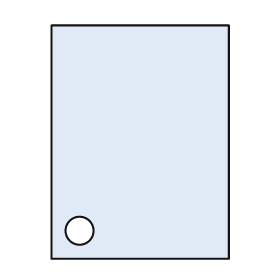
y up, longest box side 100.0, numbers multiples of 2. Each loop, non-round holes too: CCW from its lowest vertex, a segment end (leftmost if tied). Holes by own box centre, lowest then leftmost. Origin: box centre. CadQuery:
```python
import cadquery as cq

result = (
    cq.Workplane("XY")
    .moveTo(-38.0, -50.0)
    .lineTo(38.0, -50.0)
    .lineTo(38.0, 50.0)
    .lineTo(-38.0, 50.0)
    .close()
    .moveTo(-26.0, -38.0)
    .circle(6.0)
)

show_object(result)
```